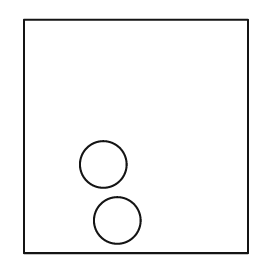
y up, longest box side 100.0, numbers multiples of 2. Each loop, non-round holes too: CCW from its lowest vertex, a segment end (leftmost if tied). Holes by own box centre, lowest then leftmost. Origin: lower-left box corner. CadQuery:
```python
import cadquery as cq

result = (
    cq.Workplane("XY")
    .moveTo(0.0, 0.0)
    .lineTo(96.0, 0.0)
    .lineTo(96.0, 100.0)
    .lineTo(0.0, 100.0)
    .close()
    .moveTo(40.0, 14.0)
    .circle(10.0)
    .moveTo(34.0, 38.0)
    .circle(10.0)
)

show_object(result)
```